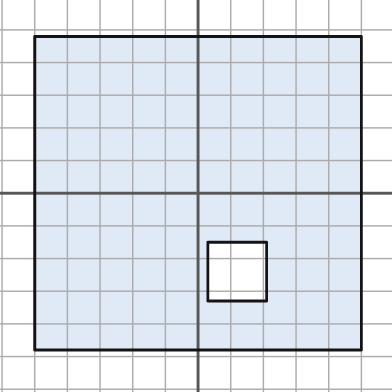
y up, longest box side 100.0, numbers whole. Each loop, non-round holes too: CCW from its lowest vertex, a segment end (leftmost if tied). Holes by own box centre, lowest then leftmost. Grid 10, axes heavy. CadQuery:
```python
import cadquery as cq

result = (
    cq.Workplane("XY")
    .moveTo(-50.0, -48.0)
    .lineTo(50.0, -48.0)
    .lineTo(50.0, 48.0)
    .lineTo(-50.0, 48.0)
    .close()
    .moveTo(3.0, -33.0)
    .lineTo(21.0, -33.0)
    .lineTo(21.0, -15.0)
    .lineTo(3.0, -15.0)
    .close()
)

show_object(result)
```